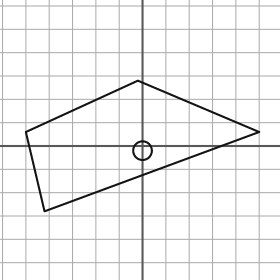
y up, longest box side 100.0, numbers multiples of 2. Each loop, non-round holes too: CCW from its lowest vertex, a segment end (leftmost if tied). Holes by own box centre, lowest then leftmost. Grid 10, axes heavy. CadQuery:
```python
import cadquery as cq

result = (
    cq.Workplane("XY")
    .moveTo(-42.0, -28.0)
    .lineTo(50.0, 6.0)
    .lineTo(-2.0, 28.0)
    .lineTo(-50.0, 6.0)
    .close()
    .moveTo(0.0, -2.0)
    .circle(4.0)
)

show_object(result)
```